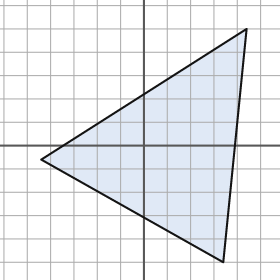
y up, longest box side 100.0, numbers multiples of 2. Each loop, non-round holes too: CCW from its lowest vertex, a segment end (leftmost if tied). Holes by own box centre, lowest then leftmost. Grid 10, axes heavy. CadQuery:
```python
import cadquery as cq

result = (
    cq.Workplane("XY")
    .moveTo(34.0, -50.0)
    .lineTo(44.0, 50.0)
    .lineTo(-44.0, -6.0)
    .close()
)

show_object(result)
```